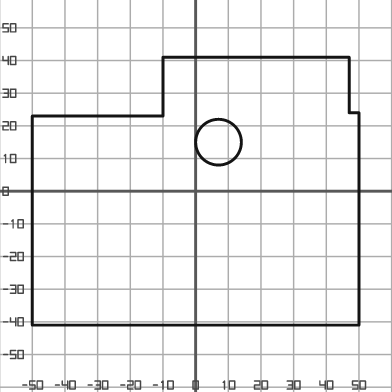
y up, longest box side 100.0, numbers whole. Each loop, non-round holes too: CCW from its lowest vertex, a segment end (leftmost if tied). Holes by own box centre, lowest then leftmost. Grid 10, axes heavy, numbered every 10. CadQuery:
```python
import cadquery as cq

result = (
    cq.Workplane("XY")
    .moveTo(-50.0, -41.0)
    .lineTo(50.0, -41.0)
    .lineTo(50.0, 24.0)
    .lineTo(47.0, 24.0)
    .lineTo(47.0, 41.0)
    .lineTo(-10.0, 41.0)
    .lineTo(-10.0, 23.0)
    .lineTo(-50.0, 23.0)
    .close()
    .moveTo(7.0, 15.0)
    .circle(7.0)
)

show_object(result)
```